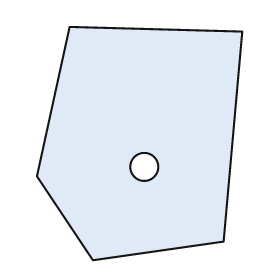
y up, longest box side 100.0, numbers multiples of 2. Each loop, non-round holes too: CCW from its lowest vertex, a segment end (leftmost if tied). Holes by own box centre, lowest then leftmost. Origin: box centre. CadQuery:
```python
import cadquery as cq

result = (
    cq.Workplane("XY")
    .moveTo(-20.0, -50.0)
    .lineTo(36.0, -42.0)
    .lineTo(44.0, 48.0)
    .lineTo(-30.0, 50.0)
    .lineTo(-44.0, -14.0)
    .close()
    .moveTo(2.0, -10.0)
    .circle(6.0)
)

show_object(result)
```